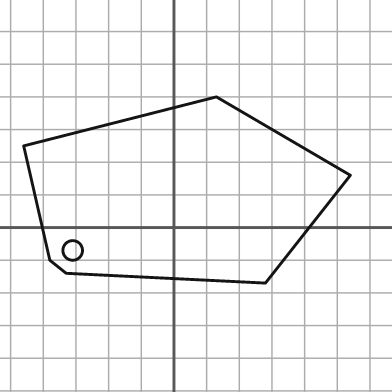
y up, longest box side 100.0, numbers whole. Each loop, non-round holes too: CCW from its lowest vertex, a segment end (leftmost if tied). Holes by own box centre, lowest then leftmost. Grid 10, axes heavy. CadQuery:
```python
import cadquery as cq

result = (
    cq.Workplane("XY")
    .moveTo(28.0, -17.0)
    .lineTo(54.0, 16.0)
    .lineTo(13.0, 40.0)
    .lineTo(-46.0, 25.0)
    .lineTo(-38.0, -10.0)
    .lineTo(-33.0, -14.0)
    .close()
    .moveTo(-31.0, -7.0)
    .circle(3.0)
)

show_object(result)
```